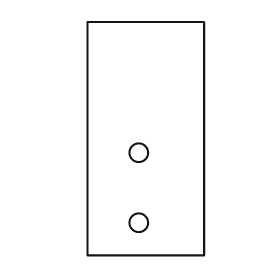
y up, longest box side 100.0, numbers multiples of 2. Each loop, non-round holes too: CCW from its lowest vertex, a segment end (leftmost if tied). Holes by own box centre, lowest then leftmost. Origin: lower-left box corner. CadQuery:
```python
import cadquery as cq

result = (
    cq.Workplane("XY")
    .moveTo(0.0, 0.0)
    .lineTo(50.0, 0.0)
    .lineTo(50.0, 100.0)
    .lineTo(0.0, 100.0)
    .close()
    .moveTo(22.0, 14.0)
    .circle(4.0)
    .moveTo(22.0, 44.0)
    .circle(4.0)
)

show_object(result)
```